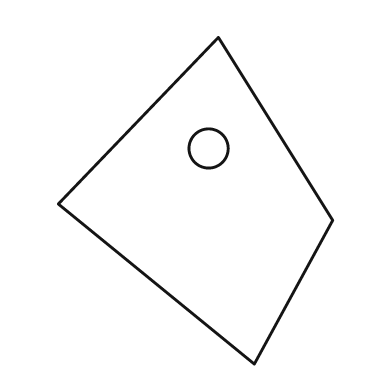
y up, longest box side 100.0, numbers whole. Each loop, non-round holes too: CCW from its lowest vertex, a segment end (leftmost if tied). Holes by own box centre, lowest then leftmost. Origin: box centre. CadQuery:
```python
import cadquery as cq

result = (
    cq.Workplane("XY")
    .moveTo(18.0, -50.0)
    .lineTo(42.0, -6.0)
    .lineTo(7.0, 50.0)
    .lineTo(-42.0, -1.0)
    .close()
    .moveTo(4.0, 16.0)
    .circle(6.0)
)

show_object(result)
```